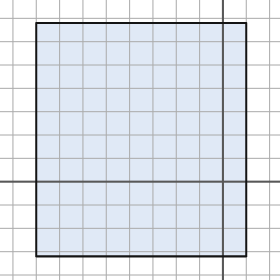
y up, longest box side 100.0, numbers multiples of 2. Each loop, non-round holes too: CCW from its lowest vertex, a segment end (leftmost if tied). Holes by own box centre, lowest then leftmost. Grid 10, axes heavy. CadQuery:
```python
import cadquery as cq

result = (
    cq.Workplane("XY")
    .moveTo(-80.0, -32.0)
    .lineTo(10.0, -32.0)
    .lineTo(10.0, 68.0)
    .lineTo(-80.0, 68.0)
    .close()
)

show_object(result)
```